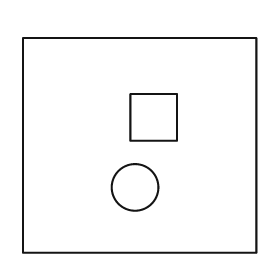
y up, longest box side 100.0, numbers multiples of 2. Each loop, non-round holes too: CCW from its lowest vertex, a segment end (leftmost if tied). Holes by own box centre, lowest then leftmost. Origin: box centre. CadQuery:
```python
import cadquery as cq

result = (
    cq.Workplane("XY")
    .moveTo(-50.0, -46.0)
    .lineTo(50.0, -46.0)
    .lineTo(50.0, 46.0)
    .lineTo(-50.0, 46.0)
    .close()
    .moveTo(-2.0, -18.0)
    .circle(10.0)
    .moveTo(-4.0, 2.0)
    .lineTo(16.0, 2.0)
    .lineTo(16.0, 22.0)
    .lineTo(-4.0, 22.0)
    .close()
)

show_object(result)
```